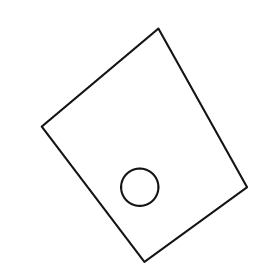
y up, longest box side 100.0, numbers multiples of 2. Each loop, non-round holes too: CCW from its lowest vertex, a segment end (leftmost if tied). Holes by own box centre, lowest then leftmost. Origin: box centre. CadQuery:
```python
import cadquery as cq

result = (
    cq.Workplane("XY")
    .moveTo(0.0, -50.0)
    .lineTo(44.0, -18.0)
    .lineTo(6.0, 50.0)
    .lineTo(-44.0, 8.0)
    .close()
    .moveTo(-2.0, -18.0)
    .circle(8.0)
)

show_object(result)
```